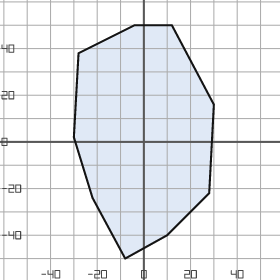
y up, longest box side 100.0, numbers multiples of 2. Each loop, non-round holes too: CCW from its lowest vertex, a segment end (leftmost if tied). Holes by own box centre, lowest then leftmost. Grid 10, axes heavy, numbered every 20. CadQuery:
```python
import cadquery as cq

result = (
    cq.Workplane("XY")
    .moveTo(-8.0, -50.0)
    .lineTo(10.0, -40.0)
    .lineTo(28.0, -22.0)
    .lineTo(30.0, 16.0)
    .lineTo(12.0, 50.0)
    .lineTo(-4.0, 50.0)
    .lineTo(-28.0, 38.0)
    .lineTo(-30.0, 2.0)
    .lineTo(-22.0, -24.0)
    .close()
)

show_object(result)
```